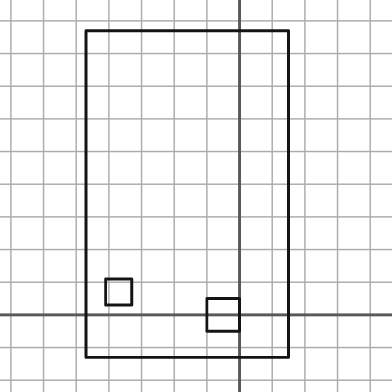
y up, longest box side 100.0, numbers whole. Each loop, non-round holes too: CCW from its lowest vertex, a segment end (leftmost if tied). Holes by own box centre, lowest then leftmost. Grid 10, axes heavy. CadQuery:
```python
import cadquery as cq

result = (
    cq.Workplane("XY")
    .moveTo(-47.0, -13.0)
    .lineTo(15.0, -13.0)
    .lineTo(15.0, 87.0)
    .lineTo(-47.0, 87.0)
    .close()
    .moveTo(-10.0, -5.0)
    .lineTo(0.0, -5.0)
    .lineTo(0.0, 5.0)
    .lineTo(-10.0, 5.0)
    .close()
    .moveTo(-41.0, 3.0)
    .lineTo(-33.0, 3.0)
    .lineTo(-33.0, 11.0)
    .lineTo(-41.0, 11.0)
    .close()
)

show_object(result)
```